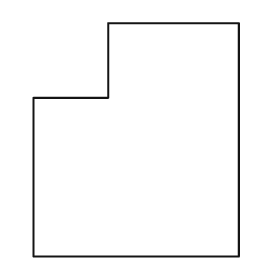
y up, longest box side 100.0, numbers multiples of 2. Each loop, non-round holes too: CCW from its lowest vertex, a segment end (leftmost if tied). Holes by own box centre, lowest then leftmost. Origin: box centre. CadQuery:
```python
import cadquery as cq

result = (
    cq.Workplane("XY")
    .moveTo(-44.0, -50.0)
    .lineTo(44.0, -50.0)
    .lineTo(44.0, 50.0)
    .lineTo(-12.0, 50.0)
    .lineTo(-12.0, 18.0)
    .lineTo(-44.0, 18.0)
    .close()
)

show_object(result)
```